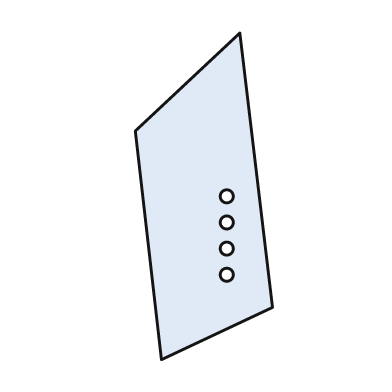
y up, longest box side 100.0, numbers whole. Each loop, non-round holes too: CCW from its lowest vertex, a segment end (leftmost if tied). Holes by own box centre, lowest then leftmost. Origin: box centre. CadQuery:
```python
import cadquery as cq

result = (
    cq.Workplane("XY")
    .moveTo(-13.0, -50.0)
    .lineTo(21.0, -34.0)
    .lineTo(11.0, 50.0)
    .lineTo(-21.0, 20.0)
    .close()
    .moveTo(7.0, -24.0)
    .circle(2.0)
    .moveTo(7.0, -16.0)
    .circle(2.0)
    .moveTo(7.0, -8.0)
    .circle(2.0)
    .moveTo(7.0, 0.0)
    .circle(2.0)
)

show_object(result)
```